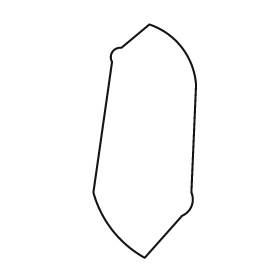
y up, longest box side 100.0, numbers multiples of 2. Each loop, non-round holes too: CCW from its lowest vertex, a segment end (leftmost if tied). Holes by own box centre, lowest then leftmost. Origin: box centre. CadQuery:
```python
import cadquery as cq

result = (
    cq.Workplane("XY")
    .moveTo(0.0, -50.0)
    .lineTo(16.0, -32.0)
    .threePointArc((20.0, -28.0), (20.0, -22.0))
    .lineTo(22.0, 24.0)
    .threePointArc((16.0, 40.0), (2.0, 50.0))
    .lineTo(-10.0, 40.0)
    .threePointArc((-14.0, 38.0), (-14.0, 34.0))
    .lineTo(-22.0, -22.0)
    .threePointArc((-14.0, -38.0), (0.0, -50.0))
    .close()
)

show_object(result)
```